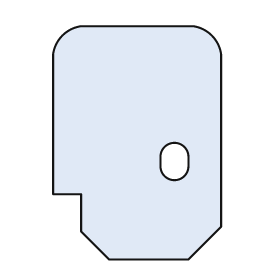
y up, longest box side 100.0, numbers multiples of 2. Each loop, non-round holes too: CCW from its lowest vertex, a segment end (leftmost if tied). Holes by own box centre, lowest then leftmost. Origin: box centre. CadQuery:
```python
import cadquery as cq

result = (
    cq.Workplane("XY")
    .moveTo(-12.0, -50.0)
    .lineTo(22.0, -50.0)
    .lineTo(36.0, -36.0)
    .lineTo(36.0, 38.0)
    .threePointArc((32.0, 46.0), (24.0, 50.0))
    .lineTo(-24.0, 50.0)
    .threePointArc((-32.0, 46.0), (-36.0, 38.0))
    .lineTo(-36.0, -22.0)
    .lineTo(-24.0, -22.0)
    .lineTo(-24.0, -38.0)
    .close()
    .moveTo(10.0, -10.0)
    .threePointArc((16.0, -16.0), (22.0, -10.0))
    .lineTo(22.0, -6.0)
    .threePointArc((16.0, 0.0), (10.0, -6.0))
    .close()
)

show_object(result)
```